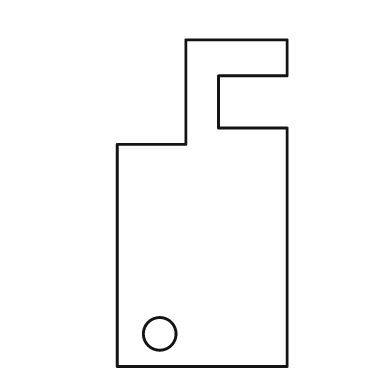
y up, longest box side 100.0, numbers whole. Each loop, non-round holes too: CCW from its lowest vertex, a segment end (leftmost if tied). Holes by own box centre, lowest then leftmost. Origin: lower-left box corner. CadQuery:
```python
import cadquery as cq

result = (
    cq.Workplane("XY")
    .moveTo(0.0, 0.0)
    .lineTo(52.0, 0.0)
    .lineTo(52.0, 73.0)
    .lineTo(31.0, 73.0)
    .lineTo(31.0, 89.0)
    .lineTo(52.0, 89.0)
    .lineTo(52.0, 100.0)
    .lineTo(21.0, 100.0)
    .lineTo(21.0, 68.0)
    .lineTo(0.0, 68.0)
    .close()
    .moveTo(13.0, 10.0)
    .circle(5.0)
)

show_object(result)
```